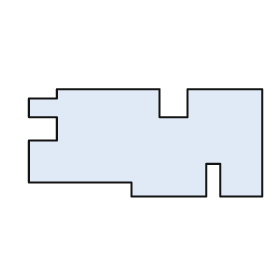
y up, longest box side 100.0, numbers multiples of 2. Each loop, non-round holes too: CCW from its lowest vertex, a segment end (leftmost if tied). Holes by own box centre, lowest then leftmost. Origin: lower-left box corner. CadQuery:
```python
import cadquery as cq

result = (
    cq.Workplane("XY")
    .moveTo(44.0, 0.0)
    .lineTo(76.0, 0.0)
    .lineTo(76.0, 14.0)
    .lineTo(82.0, 14.0)
    .lineTo(82.0, 0.0)
    .lineTo(100.0, 0.0)
    .lineTo(100.0, 46.0)
    .lineTo(68.0, 46.0)
    .lineTo(68.0, 34.0)
    .lineTo(56.0, 34.0)
    .lineTo(56.0, 46.0)
    .lineTo(12.0, 46.0)
    .lineTo(12.0, 42.0)
    .lineTo(0.0, 42.0)
    .lineTo(0.0, 34.0)
    .lineTo(12.0, 34.0)
    .lineTo(12.0, 24.0)
    .lineTo(0.0, 24.0)
    .lineTo(0.0, 6.0)
    .lineTo(44.0, 6.0)
    .close()
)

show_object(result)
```